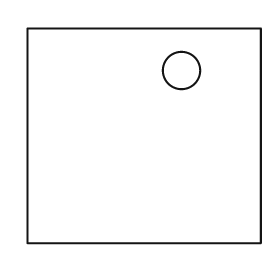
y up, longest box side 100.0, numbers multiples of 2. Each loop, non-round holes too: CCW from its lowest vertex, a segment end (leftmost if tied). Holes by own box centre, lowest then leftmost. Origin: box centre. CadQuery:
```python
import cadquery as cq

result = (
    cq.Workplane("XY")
    .moveTo(-50.0, -46.0)
    .lineTo(50.0, -46.0)
    .lineTo(50.0, 46.0)
    .lineTo(-50.0, 46.0)
    .close()
    .moveTo(16.0, 28.0)
    .circle(8.0)
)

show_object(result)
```